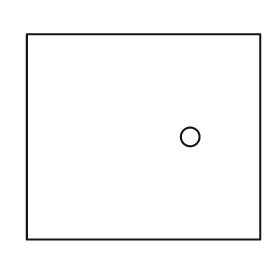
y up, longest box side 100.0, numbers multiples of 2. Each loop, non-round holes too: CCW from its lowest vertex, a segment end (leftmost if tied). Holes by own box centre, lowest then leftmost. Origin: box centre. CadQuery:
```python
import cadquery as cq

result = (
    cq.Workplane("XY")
    .moveTo(-50.0, -44.0)
    .lineTo(50.0, -44.0)
    .lineTo(50.0, 44.0)
    .lineTo(-50.0, 44.0)
    .close()
    .moveTo(20.0, 0.0)
    .circle(4.0)
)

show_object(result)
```